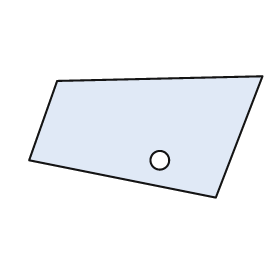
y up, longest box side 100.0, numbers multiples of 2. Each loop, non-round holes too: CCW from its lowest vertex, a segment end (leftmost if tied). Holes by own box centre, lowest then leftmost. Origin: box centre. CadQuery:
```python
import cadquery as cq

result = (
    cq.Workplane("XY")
    .moveTo(30.0, -26.0)
    .lineTo(50.0, 26.0)
    .lineTo(-38.0, 24.0)
    .lineTo(-50.0, -10.0)
    .close()
    .moveTo(6.0, -10.0)
    .circle(4.0)
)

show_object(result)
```